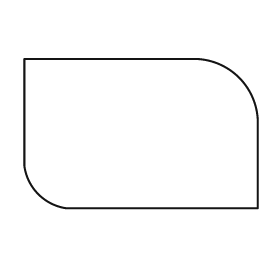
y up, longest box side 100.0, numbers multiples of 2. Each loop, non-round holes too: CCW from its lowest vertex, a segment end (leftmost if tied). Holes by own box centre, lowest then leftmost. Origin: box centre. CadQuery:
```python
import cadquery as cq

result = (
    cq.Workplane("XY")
    .moveTo(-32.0, -32.0)
    .lineTo(50.0, -32.0)
    .lineTo(50.0, 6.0)
    .threePointArc((42.0, 24.0), (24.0, 32.0))
    .lineTo(-50.0, 32.0)
    .lineTo(-50.0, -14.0)
    .threePointArc((-44.0, -26.0), (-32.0, -32.0))
    .close()
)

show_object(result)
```